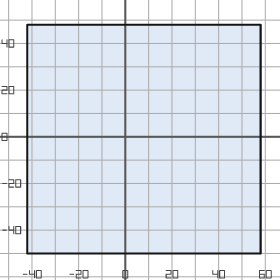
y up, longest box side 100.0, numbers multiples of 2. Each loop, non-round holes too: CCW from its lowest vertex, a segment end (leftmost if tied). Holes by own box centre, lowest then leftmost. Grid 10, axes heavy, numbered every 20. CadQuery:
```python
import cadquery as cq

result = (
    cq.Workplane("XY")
    .moveTo(-42.0, -50.0)
    .lineTo(58.0, -50.0)
    .lineTo(58.0, 48.0)
    .lineTo(-42.0, 48.0)
    .close()
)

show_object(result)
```